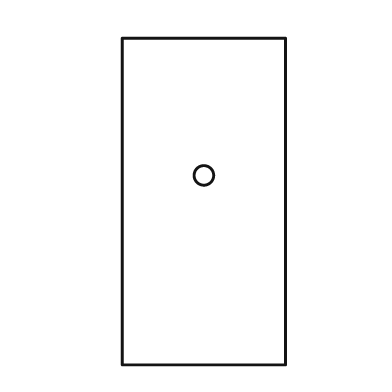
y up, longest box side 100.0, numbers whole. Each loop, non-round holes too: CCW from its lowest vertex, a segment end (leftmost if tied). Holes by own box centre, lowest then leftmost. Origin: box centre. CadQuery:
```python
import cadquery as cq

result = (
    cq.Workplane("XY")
    .moveTo(-25.0, -50.0)
    .lineTo(25.0, -50.0)
    .lineTo(25.0, 50.0)
    .lineTo(-25.0, 50.0)
    .close()
    .moveTo(0.0, 8.0)
    .circle(3.0)
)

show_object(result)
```